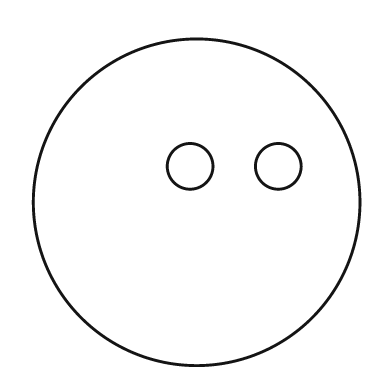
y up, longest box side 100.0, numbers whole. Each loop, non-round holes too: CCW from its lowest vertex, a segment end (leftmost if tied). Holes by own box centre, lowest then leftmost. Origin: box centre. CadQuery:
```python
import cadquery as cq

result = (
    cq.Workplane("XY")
    .moveTo(0.0, 0.0)
    .circle(50.0)
    .moveTo(-2.0, 11.0)
    .circle(7.0)
    .moveTo(25.0, 11.0)
    .circle(7.0)
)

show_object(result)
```